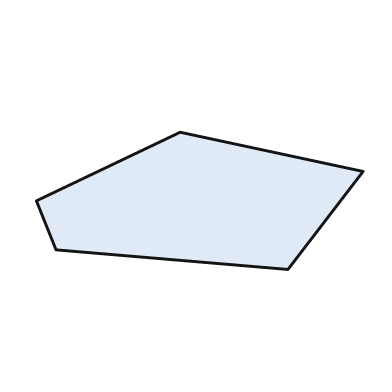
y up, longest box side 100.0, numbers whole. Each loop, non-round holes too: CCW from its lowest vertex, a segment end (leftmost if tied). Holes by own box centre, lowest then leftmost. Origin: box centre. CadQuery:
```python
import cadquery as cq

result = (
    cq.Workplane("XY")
    .moveTo(27.0, -21.0)
    .lineTo(50.0, 9.0)
    .lineTo(-6.0, 21.0)
    .lineTo(-50.0, 0.0)
    .lineTo(-44.0, -15.0)
    .close()
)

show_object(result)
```